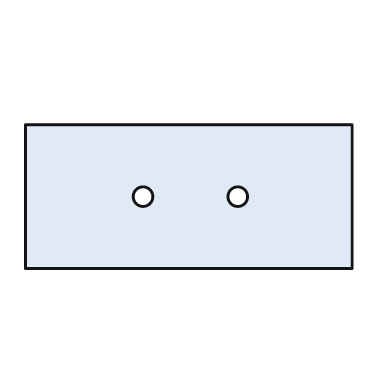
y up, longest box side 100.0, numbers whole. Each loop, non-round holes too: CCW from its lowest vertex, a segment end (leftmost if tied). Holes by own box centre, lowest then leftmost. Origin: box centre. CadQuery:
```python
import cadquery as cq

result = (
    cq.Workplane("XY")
    .moveTo(-50.0, -22.0)
    .lineTo(50.0, -22.0)
    .lineTo(50.0, 22.0)
    .lineTo(-50.0, 22.0)
    .close()
    .moveTo(-14.0, 0.0)
    .circle(3.0)
    .moveTo(15.0, 0.0)
    .circle(3.0)
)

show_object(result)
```